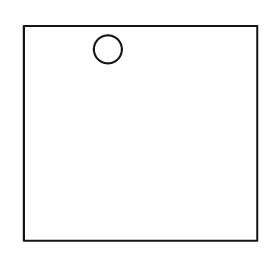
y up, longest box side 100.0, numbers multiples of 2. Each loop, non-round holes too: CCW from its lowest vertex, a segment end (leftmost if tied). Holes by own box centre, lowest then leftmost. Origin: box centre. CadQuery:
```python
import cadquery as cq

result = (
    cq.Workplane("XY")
    .moveTo(-50.0, -46.0)
    .lineTo(50.0, -46.0)
    .lineTo(50.0, 46.0)
    .lineTo(-50.0, 46.0)
    .close()
    .moveTo(-14.0, 36.0)
    .circle(6.0)
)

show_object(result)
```